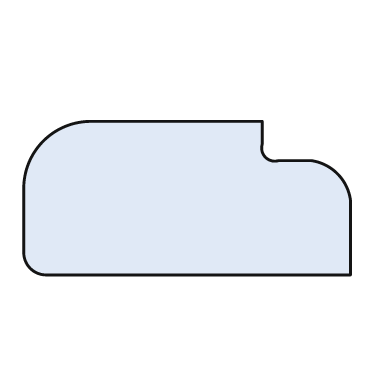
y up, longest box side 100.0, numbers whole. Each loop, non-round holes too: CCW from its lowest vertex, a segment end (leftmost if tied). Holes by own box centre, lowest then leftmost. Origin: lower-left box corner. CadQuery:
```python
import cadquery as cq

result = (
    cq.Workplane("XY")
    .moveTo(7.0, 0.0)
    .lineTo(100.0, 0.0)
    .lineTo(100.0, 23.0)
    .threePointArc((96.0, 31.0), (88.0, 35.0))
    .lineTo(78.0, 35.0)
    .threePointArc((74.0, 36.0), (73.0, 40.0))
    .lineTo(73.0, 47.0)
    .lineTo(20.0, 47.0)
    .threePointArc((6.0, 41.0), (0.0, 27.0))
    .lineTo(0.0, 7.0)
    .threePointArc((2.0, 2.0), (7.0, 0.0))
    .close()
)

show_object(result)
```